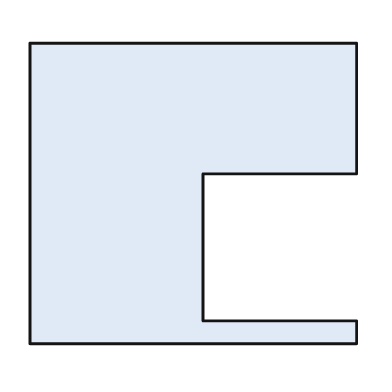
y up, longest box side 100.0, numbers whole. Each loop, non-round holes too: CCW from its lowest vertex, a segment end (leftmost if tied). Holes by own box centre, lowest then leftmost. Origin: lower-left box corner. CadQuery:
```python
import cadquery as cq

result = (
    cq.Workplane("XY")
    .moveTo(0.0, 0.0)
    .lineTo(100.0, 0.0)
    .lineTo(100.0, 7.0)
    .lineTo(53.0, 7.0)
    .lineTo(53.0, 52.0)
    .lineTo(100.0, 52.0)
    .lineTo(100.0, 92.0)
    .lineTo(0.0, 92.0)
    .close()
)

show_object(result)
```